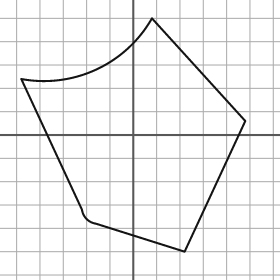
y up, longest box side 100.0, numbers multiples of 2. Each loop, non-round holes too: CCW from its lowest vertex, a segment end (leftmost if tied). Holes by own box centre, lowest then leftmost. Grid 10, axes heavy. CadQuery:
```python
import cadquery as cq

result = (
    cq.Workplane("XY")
    .moveTo(22.0, -50.0)
    .lineTo(48.0, 6.0)
    .lineTo(8.0, 50.0)
    .threePointArc((-16.0, 28.0), (-48.0, 24.0))
    .lineTo(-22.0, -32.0)
    .threePointArc((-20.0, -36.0), (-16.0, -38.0))
    .close()
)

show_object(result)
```